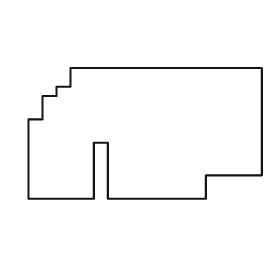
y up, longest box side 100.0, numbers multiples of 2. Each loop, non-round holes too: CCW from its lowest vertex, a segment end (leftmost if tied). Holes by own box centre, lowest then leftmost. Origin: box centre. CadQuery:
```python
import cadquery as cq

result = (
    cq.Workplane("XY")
    .moveTo(-50.0, -28.0)
    .lineTo(-22.0, -28.0)
    .lineTo(-22.0, -4.0)
    .lineTo(-16.0, -4.0)
    .lineTo(-16.0, -28.0)
    .lineTo(26.0, -28.0)
    .lineTo(26.0, -18.0)
    .lineTo(50.0, -18.0)
    .lineTo(50.0, 28.0)
    .lineTo(-32.0, 28.0)
    .lineTo(-32.0, 20.0)
    .lineTo(-38.0, 20.0)
    .lineTo(-38.0, 16.0)
    .lineTo(-44.0, 16.0)
    .lineTo(-44.0, 6.0)
    .lineTo(-50.0, 6.0)
    .close()
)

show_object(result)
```